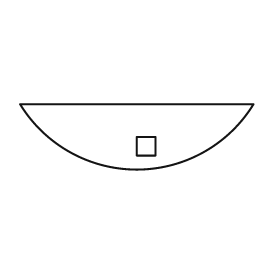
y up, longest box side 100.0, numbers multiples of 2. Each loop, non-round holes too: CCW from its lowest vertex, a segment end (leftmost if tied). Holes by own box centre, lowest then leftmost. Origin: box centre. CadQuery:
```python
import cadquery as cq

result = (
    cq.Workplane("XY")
    .moveTo(-50.0, 14.0)
    .threePointArc((0.0, -14.0), (50.0, 14.0))
    .close()
    .moveTo(0.0, -8.0)
    .lineTo(8.0, -8.0)
    .lineTo(8.0, 0.0)
    .lineTo(0.0, 0.0)
    .close()
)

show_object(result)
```